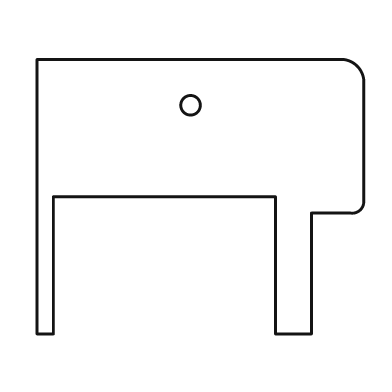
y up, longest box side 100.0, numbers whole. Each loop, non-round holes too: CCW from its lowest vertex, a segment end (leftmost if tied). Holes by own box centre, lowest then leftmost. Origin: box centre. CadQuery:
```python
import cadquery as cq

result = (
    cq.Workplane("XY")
    .moveTo(-50.0, -42.0)
    .lineTo(-45.0, -42.0)
    .lineTo(-45.0, 0.0)
    .lineTo(23.0, 0.0)
    .lineTo(23.0, -42.0)
    .lineTo(34.0, -42.0)
    .lineTo(34.0, -5.0)
    .lineTo(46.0, -5.0)
    .threePointArc((49.0, -4.0), (50.0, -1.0))
    .lineTo(50.0, 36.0)
    .threePointArc((48.0, 40.0), (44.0, 42.0))
    .lineTo(-50.0, 42.0)
    .close()
    .moveTo(-3.0, 28.0)
    .circle(3.0)
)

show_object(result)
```